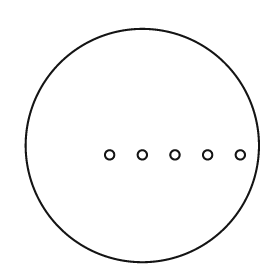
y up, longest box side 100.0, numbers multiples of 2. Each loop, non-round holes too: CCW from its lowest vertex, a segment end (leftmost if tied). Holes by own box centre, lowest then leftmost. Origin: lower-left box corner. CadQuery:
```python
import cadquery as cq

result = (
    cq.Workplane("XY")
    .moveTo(50.0, 50.0)
    .circle(50.0)
    .moveTo(36.0, 46.0)
    .circle(2.0)
    .moveTo(50.0, 46.0)
    .circle(2.0)
    .moveTo(64.0, 46.0)
    .circle(2.0)
    .moveTo(78.0, 46.0)
    .circle(2.0)
    .moveTo(92.0, 46.0)
    .circle(2.0)
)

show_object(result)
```